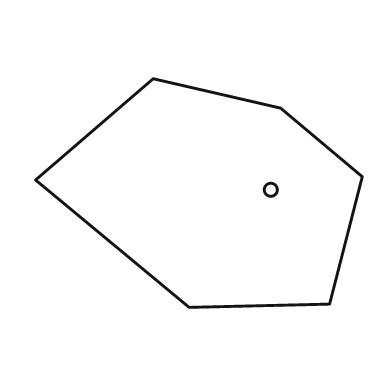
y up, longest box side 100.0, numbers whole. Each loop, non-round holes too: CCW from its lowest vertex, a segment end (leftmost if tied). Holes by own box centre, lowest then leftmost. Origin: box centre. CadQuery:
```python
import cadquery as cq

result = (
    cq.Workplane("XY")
    .moveTo(-3.0, -35.0)
    .lineTo(40.0, -34.0)
    .lineTo(50.0, 5.0)
    .lineTo(25.0, 26.0)
    .lineTo(-14.0, 35.0)
    .lineTo(-50.0, 4.0)
    .close()
    .moveTo(22.0, 1.0)
    .circle(2.0)
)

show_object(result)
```